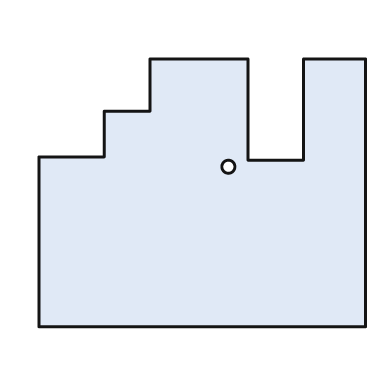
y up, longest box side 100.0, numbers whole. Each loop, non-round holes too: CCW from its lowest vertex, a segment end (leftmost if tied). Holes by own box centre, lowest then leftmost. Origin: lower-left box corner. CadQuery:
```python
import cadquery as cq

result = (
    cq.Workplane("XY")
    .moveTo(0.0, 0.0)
    .lineTo(100.0, 0.0)
    .lineTo(100.0, 82.0)
    .lineTo(81.0, 82.0)
    .lineTo(81.0, 51.0)
    .lineTo(64.0, 51.0)
    .lineTo(64.0, 82.0)
    .lineTo(34.0, 82.0)
    .lineTo(34.0, 66.0)
    .lineTo(20.0, 66.0)
    .lineTo(20.0, 52.0)
    .lineTo(0.0, 52.0)
    .close()
    .moveTo(58.0, 49.0)
    .circle(2.0)
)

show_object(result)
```